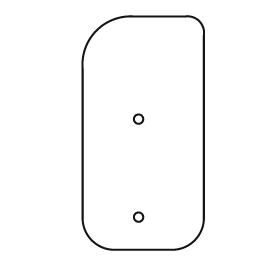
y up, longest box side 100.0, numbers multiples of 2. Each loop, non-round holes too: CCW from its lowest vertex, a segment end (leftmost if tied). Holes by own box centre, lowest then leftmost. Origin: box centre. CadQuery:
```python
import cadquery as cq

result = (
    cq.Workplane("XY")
    .moveTo(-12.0, -50.0)
    .lineTo(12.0, -50.0)
    .threePointArc((22.0, -46.0), (26.0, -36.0))
    .lineTo(26.0, 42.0)
    .threePointArc((24.0, 48.0), (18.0, 50.0))
    .lineTo(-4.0, 50.0)
    .threePointArc((-20.0, 44.0), (-26.0, 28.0))
    .lineTo(-26.0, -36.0)
    .threePointArc((-22.0, -46.0), (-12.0, -50.0))
    .close()
    .moveTo(-2.0, -36.0)
    .circle(2.0)
    .moveTo(-2.0, 6.0)
    .circle(2.0)
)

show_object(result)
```